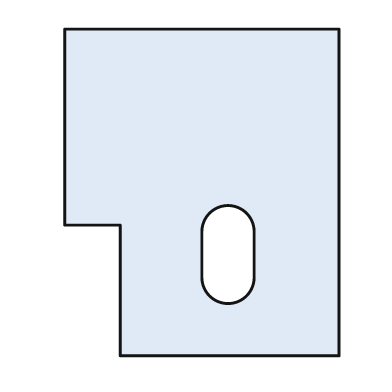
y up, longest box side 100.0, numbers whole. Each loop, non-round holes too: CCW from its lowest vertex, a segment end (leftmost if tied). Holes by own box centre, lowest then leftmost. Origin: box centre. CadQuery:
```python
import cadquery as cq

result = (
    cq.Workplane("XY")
    .moveTo(-25.0, -50.0)
    .lineTo(42.0, -50.0)
    .lineTo(42.0, 50.0)
    .lineTo(-42.0, 50.0)
    .lineTo(-42.0, -10.0)
    .lineTo(-25.0, -10.0)
    .close()
    .moveTo(0.0, -26.0)
    .threePointArc((8.0, -34.0), (16.0, -26.0))
    .lineTo(16.0, -12.0)
    .threePointArc((8.0, -4.0), (0.0, -12.0))
    .close()
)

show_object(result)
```